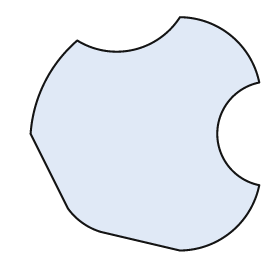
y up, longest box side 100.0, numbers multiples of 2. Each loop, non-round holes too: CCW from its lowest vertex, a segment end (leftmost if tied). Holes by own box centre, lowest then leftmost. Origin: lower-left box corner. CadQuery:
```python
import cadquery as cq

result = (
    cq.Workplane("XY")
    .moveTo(64.0, 0.0)
    .threePointArc((86.0, 8.0), (98.0, 28.0))
    .threePointArc((80.0, 50.0), (98.0, 72.0))
    .threePointArc((86.0, 92.0), (64.0, 100.0))
    .threePointArc((44.0, 86.0), (20.0, 90.0))
    .threePointArc((6.0, 72.0), (0.0, 50.0))
    .lineTo(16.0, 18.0)
    .threePointArc((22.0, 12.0), (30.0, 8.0))
    .close()
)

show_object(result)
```